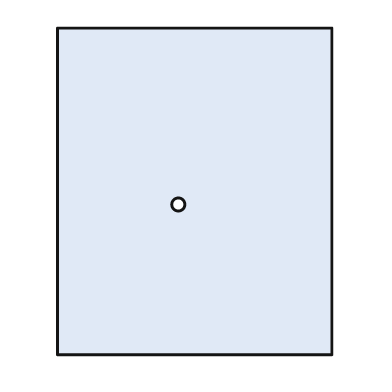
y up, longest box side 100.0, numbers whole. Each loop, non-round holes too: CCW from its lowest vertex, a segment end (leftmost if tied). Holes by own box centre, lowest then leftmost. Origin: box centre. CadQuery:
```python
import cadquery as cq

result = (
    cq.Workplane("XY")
    .moveTo(-42.0, -50.0)
    .lineTo(42.0, -50.0)
    .lineTo(42.0, 50.0)
    .lineTo(-42.0, 50.0)
    .close()
    .moveTo(-5.0, -4.0)
    .circle(2.0)
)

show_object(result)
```